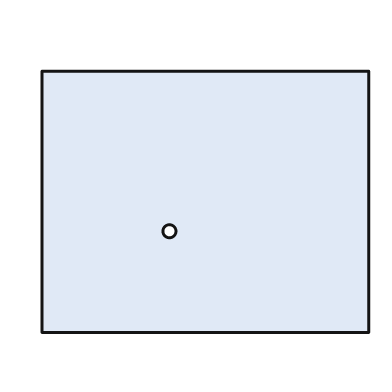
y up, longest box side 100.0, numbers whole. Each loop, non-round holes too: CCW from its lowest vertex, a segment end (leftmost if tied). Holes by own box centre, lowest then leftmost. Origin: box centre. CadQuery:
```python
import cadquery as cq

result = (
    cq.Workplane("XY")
    .moveTo(-50.0, -40.0)
    .lineTo(50.0, -40.0)
    .lineTo(50.0, 40.0)
    .lineTo(-50.0, 40.0)
    .close()
    .moveTo(-11.0, -9.0)
    .circle(2.0)
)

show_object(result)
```